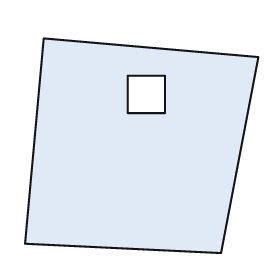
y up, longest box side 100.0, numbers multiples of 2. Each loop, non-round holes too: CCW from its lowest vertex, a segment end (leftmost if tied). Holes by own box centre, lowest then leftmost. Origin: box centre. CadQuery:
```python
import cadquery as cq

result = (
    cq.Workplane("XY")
    .moveTo(34.0, -46.0)
    .lineTo(50.0, 38.0)
    .lineTo(-42.0, 46.0)
    .lineTo(-50.0, -42.0)
    .close()
    .moveTo(-6.0, 14.0)
    .lineTo(10.0, 14.0)
    .lineTo(10.0, 30.0)
    .lineTo(-6.0, 30.0)
    .close()
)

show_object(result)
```